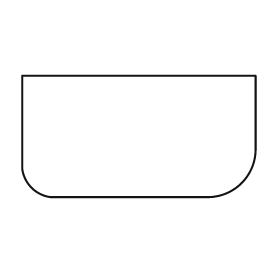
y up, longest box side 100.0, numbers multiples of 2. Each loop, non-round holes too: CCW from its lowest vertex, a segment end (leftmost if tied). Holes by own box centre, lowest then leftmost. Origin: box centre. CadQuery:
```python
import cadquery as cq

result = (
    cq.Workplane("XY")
    .moveTo(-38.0, -26.0)
    .lineTo(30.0, -26.0)
    .threePointArc((44.0, -20.0), (50.0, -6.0))
    .lineTo(50.0, 26.0)
    .lineTo(-50.0, 26.0)
    .lineTo(-50.0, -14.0)
    .threePointArc((-46.0, -22.0), (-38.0, -26.0))
    .close()
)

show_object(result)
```